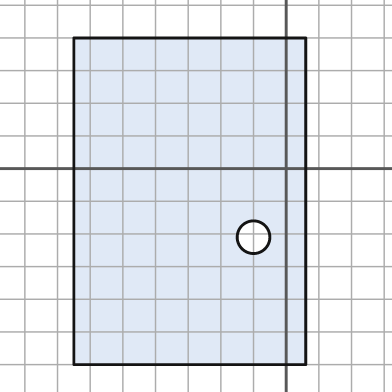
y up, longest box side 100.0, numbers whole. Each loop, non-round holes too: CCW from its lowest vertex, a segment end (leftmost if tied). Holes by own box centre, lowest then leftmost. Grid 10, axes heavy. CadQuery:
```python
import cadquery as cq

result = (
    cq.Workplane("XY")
    .moveTo(-65.0, -60.0)
    .lineTo(6.0, -60.0)
    .lineTo(6.0, 40.0)
    .lineTo(-65.0, 40.0)
    .close()
    .moveTo(-10.0, -21.0)
    .circle(5.0)
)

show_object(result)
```